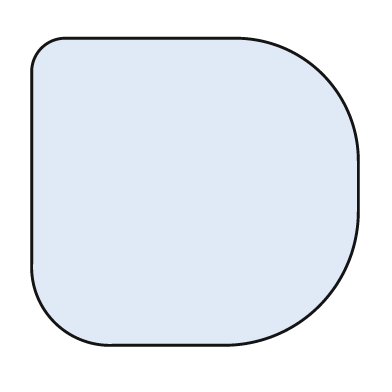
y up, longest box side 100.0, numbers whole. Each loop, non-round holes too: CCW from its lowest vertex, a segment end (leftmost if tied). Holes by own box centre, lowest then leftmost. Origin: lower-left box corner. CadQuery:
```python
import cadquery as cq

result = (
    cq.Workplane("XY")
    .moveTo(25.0, 0.0)
    .lineTo(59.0, 0.0)
    .threePointArc((88.0, 12.0), (100.0, 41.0))
    .lineTo(100.0, 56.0)
    .threePointArc((89.0, 83.0), (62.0, 94.0))
    .lineTo(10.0, 94.0)
    .threePointArc((3.0, 91.0), (0.0, 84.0))
    .lineTo(0.0, 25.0)
    .threePointArc((7.0, 7.0), (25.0, 0.0))
    .close()
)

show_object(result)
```